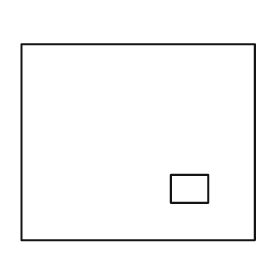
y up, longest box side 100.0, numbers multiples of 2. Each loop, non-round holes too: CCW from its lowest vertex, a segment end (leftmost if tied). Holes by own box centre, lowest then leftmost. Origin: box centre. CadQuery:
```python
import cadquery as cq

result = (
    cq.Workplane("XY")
    .moveTo(-50.0, -42.0)
    .lineTo(50.0, -42.0)
    .lineTo(50.0, 42.0)
    .lineTo(-50.0, 42.0)
    .close()
    .moveTo(14.0, -26.0)
    .lineTo(30.0, -26.0)
    .lineTo(30.0, -14.0)
    .lineTo(14.0, -14.0)
    .close()
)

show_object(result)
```